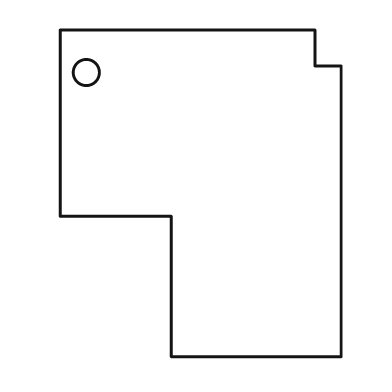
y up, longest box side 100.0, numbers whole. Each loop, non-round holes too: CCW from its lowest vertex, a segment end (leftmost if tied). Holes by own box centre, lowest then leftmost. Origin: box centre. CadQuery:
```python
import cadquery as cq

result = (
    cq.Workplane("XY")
    .moveTo(-9.0, -50.0)
    .lineTo(43.0, -50.0)
    .lineTo(43.0, 39.0)
    .lineTo(35.0, 39.0)
    .lineTo(35.0, 50.0)
    .lineTo(-43.0, 50.0)
    .lineTo(-43.0, -7.0)
    .lineTo(-9.0, -7.0)
    .close()
    .moveTo(-35.0, 37.0)
    .circle(4.0)
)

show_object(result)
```